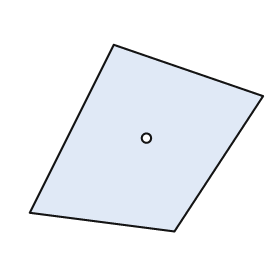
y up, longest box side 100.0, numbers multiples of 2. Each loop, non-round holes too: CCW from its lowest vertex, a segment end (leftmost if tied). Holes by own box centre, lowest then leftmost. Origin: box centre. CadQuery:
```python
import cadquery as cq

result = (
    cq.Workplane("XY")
    .moveTo(12.0, -40.0)
    .lineTo(50.0, 18.0)
    .lineTo(-14.0, 40.0)
    .lineTo(-50.0, -32.0)
    .close()
    .moveTo(0.0, 0.0)
    .circle(2.0)
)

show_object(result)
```